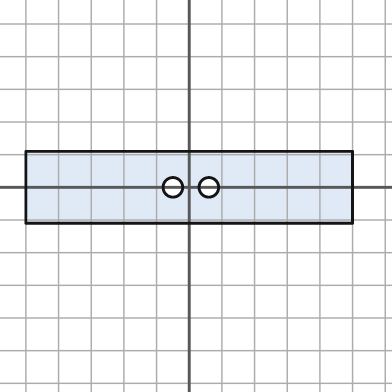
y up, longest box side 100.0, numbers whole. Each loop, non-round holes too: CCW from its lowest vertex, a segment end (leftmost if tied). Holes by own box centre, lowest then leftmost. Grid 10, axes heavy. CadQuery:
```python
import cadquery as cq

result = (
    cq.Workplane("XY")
    .moveTo(-50.0, -11.0)
    .lineTo(50.0, -11.0)
    .lineTo(50.0, 11.0)
    .lineTo(-50.0, 11.0)
    .close()
    .moveTo(-5.0, 0.0)
    .circle(3.0)
    .moveTo(6.0, 0.0)
    .circle(3.0)
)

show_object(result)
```